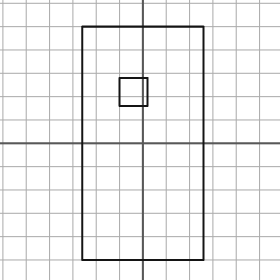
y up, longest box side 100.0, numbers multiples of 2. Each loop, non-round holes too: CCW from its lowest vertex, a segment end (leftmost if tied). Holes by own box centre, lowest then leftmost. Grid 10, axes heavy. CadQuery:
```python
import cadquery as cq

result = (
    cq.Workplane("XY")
    .moveTo(-26.0, -50.0)
    .lineTo(26.0, -50.0)
    .lineTo(26.0, 50.0)
    .lineTo(-26.0, 50.0)
    .close()
    .moveTo(-10.0, 16.0)
    .lineTo(2.0, 16.0)
    .lineTo(2.0, 28.0)
    .lineTo(-10.0, 28.0)
    .close()
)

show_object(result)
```